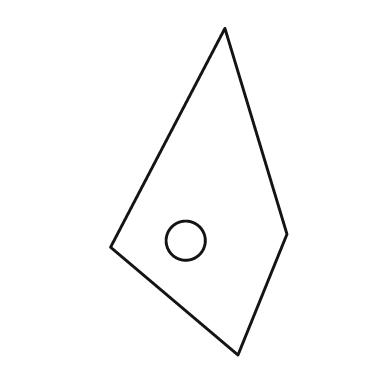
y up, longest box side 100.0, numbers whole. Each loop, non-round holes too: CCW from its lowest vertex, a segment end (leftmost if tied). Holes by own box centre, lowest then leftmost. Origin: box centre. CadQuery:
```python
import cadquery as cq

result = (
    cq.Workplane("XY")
    .moveTo(12.0, -50.0)
    .lineTo(27.0, -13.0)
    .lineTo(8.0, 50.0)
    .lineTo(-27.0, -17.0)
    .close()
    .moveTo(-4.0, -15.0)
    .circle(6.0)
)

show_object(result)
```